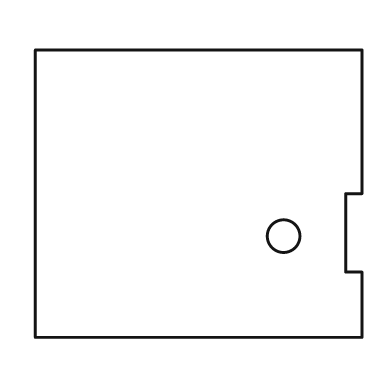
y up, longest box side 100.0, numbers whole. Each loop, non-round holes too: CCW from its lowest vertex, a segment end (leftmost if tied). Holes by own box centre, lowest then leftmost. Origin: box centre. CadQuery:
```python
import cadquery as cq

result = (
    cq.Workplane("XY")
    .moveTo(-50.0, -44.0)
    .lineTo(50.0, -44.0)
    .lineTo(50.0, -24.0)
    .lineTo(45.0, -24.0)
    .lineTo(45.0, 0.0)
    .lineTo(50.0, 0.0)
    .lineTo(50.0, 44.0)
    .lineTo(-50.0, 44.0)
    .close()
    .moveTo(26.0, -13.0)
    .circle(5.0)
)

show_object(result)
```